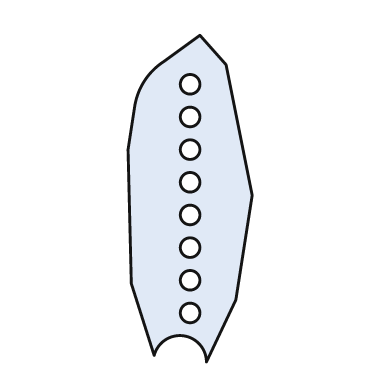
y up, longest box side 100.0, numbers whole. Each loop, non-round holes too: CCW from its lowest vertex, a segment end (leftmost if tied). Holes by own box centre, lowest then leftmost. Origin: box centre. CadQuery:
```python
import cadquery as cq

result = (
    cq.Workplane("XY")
    .moveTo(5.0, -50.0)
    .lineTo(14.0, -31.0)
    .lineTo(19.0, 1.0)
    .lineTo(11.0, 41.0)
    .lineTo(3.0, 50.0)
    .lineTo(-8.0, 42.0)
    .threePointArc((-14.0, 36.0), (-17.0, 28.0))
    .lineTo(-19.0, 15.0)
    .lineTo(-18.0, -26.0)
    .lineTo(-11.0, -48.0)
    .threePointArc((-2.0, -42.0), (5.0, -50.0))
    .close()
    .moveTo(0.0, -35.0)
    .circle(3.0)
    .moveTo(0.0, -25.0)
    .circle(3.0)
    .moveTo(0.0, -15.0)
    .circle(3.0)
    .moveTo(0.0, -5.0)
    .circle(3.0)
    .moveTo(0.0, 5.0)
    .circle(3.0)
    .moveTo(0.0, 15.0)
    .circle(3.0)
    .moveTo(0.0, 25.0)
    .circle(3.0)
    .moveTo(0.0, 35.0)
    .circle(3.0)
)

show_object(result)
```